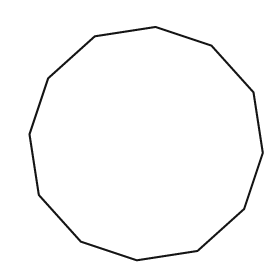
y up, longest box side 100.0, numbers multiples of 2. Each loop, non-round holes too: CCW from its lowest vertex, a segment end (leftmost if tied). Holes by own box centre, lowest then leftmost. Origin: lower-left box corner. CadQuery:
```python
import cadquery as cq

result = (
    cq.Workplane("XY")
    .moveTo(46.0, 0.0)
    .lineTo(72.0, 4.0)
    .lineTo(92.0, 22.0)
    .lineTo(100.0, 46.0)
    .lineTo(96.0, 72.0)
    .lineTo(78.0, 92.0)
    .lineTo(54.0, 100.0)
    .lineTo(28.0, 96.0)
    .lineTo(8.0, 78.0)
    .lineTo(0.0, 54.0)
    .lineTo(4.0, 28.0)
    .lineTo(22.0, 8.0)
    .close()
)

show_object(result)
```